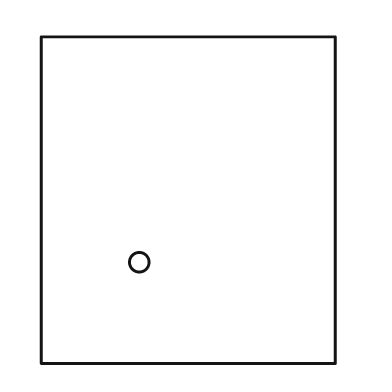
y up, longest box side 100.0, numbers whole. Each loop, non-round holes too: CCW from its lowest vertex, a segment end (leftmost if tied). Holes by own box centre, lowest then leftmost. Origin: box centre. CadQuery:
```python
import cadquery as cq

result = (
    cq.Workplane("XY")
    .moveTo(-45.0, -50.0)
    .lineTo(45.0, -50.0)
    .lineTo(45.0, 50.0)
    .lineTo(-45.0, 50.0)
    .close()
    .moveTo(-15.0, -19.0)
    .circle(3.0)
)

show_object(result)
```